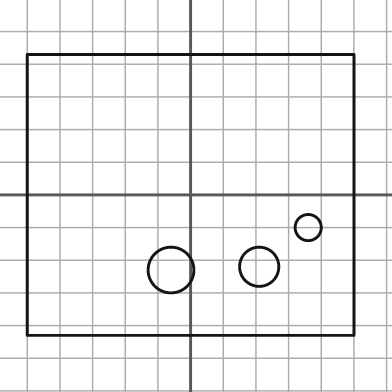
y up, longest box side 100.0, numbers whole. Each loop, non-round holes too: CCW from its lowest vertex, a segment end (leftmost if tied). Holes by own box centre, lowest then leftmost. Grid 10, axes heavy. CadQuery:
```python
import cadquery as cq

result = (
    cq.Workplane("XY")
    .moveTo(-50.0, -43.0)
    .lineTo(50.0, -43.0)
    .lineTo(50.0, 43.0)
    .lineTo(-50.0, 43.0)
    .close()
    .moveTo(-6.0, -23.0)
    .circle(7.0)
    .moveTo(21.0, -22.0)
    .circle(6.0)
    .moveTo(36.0, -10.0)
    .circle(4.0)
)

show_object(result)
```